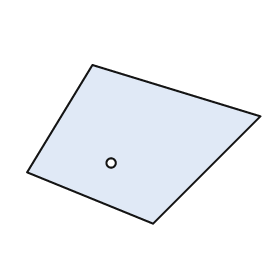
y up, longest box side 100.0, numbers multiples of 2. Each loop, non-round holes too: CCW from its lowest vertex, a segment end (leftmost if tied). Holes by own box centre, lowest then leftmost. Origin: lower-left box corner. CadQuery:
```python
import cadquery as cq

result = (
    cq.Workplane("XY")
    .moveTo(54.0, 0.0)
    .lineTo(100.0, 46.0)
    .lineTo(28.0, 68.0)
    .lineTo(0.0, 22.0)
    .close()
    .moveTo(36.0, 26.0)
    .circle(2.0)
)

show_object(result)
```